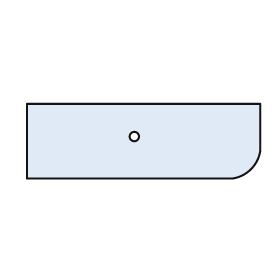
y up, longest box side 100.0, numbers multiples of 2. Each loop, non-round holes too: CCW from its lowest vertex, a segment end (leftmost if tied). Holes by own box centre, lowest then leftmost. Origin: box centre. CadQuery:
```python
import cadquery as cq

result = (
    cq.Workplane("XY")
    .moveTo(-50.0, -16.0)
    .lineTo(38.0, -16.0)
    .threePointArc((46.0, -12.0), (50.0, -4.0))
    .lineTo(50.0, 16.0)
    .lineTo(-50.0, 16.0)
    .close()
    .moveTo(-4.0, 2.0)
    .circle(2.0)
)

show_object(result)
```